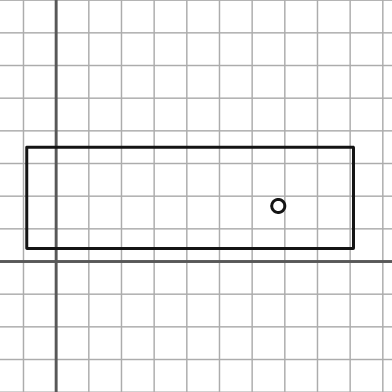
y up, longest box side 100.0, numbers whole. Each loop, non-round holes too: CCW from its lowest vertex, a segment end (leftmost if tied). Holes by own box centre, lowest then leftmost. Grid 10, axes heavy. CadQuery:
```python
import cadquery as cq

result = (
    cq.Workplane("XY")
    .moveTo(-9.0, 4.0)
    .lineTo(91.0, 4.0)
    .lineTo(91.0, 35.0)
    .lineTo(-9.0, 35.0)
    .close()
    .moveTo(68.0, 17.0)
    .circle(2.0)
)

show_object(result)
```